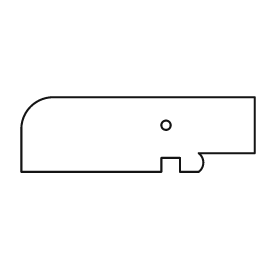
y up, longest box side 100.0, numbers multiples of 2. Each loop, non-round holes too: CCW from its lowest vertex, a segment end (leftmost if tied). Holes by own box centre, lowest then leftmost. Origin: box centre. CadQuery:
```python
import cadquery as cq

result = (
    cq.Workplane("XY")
    .moveTo(-50.0, -16.0)
    .lineTo(10.0, -16.0)
    .lineTo(10.0, -10.0)
    .lineTo(18.0, -10.0)
    .lineTo(18.0, -16.0)
    .lineTo(26.0, -16.0)
    .threePointArc((28.0, -12.0), (26.0, -8.0))
    .lineTo(50.0, -8.0)
    .lineTo(50.0, 16.0)
    .lineTo(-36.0, 16.0)
    .threePointArc((-46.0, 12.0), (-50.0, 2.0))
    .close()
    .moveTo(12.0, 4.0)
    .circle(2.0)
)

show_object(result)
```